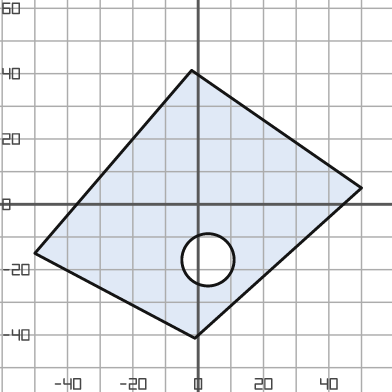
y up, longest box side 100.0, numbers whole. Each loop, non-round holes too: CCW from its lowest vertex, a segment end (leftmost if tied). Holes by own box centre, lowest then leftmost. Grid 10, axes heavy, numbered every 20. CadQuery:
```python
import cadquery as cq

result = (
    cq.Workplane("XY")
    .moveTo(-1.0, -41.0)
    .lineTo(50.0, 5.0)
    .lineTo(-2.0, 41.0)
    .lineTo(-50.0, -15.0)
    .close()
    .moveTo(3.0, -17.0)
    .circle(8.0)
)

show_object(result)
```